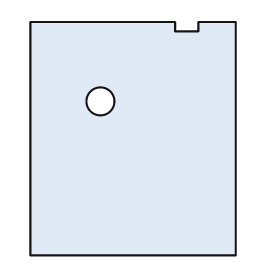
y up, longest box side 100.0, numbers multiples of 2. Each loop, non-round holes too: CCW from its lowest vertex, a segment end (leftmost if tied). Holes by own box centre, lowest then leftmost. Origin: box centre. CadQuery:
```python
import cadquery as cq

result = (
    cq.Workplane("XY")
    .moveTo(-44.0, -50.0)
    .lineTo(44.0, -50.0)
    .lineTo(44.0, 50.0)
    .lineTo(28.0, 50.0)
    .lineTo(28.0, 46.0)
    .lineTo(18.0, 46.0)
    .lineTo(18.0, 50.0)
    .lineTo(-44.0, 50.0)
    .close()
    .moveTo(-14.0, 16.0)
    .circle(6.0)
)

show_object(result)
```